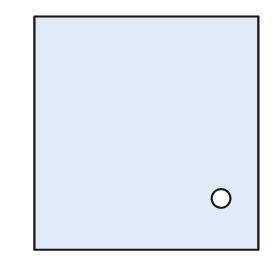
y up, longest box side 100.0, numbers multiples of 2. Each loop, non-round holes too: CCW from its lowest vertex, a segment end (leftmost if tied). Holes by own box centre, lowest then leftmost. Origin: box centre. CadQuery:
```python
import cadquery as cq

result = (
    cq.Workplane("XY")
    .moveTo(-48.0, -50.0)
    .lineTo(48.0, -50.0)
    .lineTo(48.0, 50.0)
    .lineTo(-48.0, 50.0)
    .close()
    .moveTo(32.0, -28.0)
    .circle(4.0)
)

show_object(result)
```